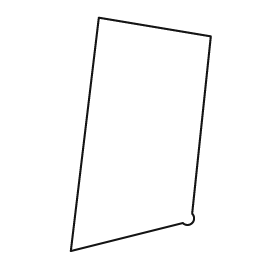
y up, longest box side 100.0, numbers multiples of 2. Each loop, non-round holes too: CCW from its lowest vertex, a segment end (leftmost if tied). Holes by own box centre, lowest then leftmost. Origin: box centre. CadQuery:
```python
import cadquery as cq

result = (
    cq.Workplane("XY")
    .moveTo(-30.0, -50.0)
    .lineTo(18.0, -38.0)
    .threePointArc((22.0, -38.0), (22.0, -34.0))
    .lineTo(30.0, 42.0)
    .lineTo(-18.0, 50.0)
    .close()
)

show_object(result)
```